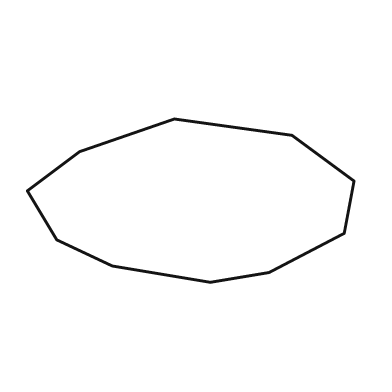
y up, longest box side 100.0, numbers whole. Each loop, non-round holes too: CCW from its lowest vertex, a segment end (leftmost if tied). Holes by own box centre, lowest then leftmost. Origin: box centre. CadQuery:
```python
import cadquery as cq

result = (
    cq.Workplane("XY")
    .moveTo(6.0, -25.0)
    .lineTo(24.0, -22.0)
    .lineTo(47.0, -10.0)
    .lineTo(50.0, 6.0)
    .lineTo(31.0, 20.0)
    .lineTo(-5.0, 25.0)
    .lineTo(-34.0, 15.0)
    .lineTo(-50.0, 3.0)
    .lineTo(-41.0, -12.0)
    .lineTo(-24.0, -20.0)
    .close()
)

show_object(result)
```